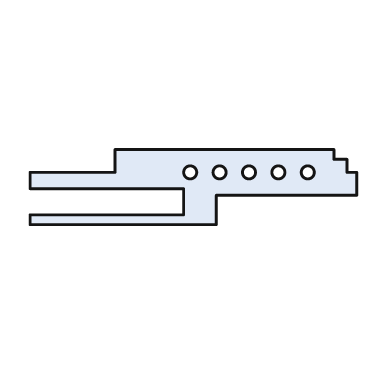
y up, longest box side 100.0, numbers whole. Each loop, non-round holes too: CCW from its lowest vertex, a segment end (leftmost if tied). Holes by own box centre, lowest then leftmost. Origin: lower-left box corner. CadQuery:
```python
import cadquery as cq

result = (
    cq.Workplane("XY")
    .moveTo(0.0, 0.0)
    .lineTo(57.0, 0.0)
    .lineTo(57.0, 9.0)
    .lineTo(100.0, 9.0)
    .lineTo(100.0, 16.0)
    .lineTo(97.0, 16.0)
    .lineTo(97.0, 20.0)
    .lineTo(93.0, 20.0)
    .lineTo(93.0, 23.0)
    .lineTo(26.0, 23.0)
    .lineTo(26.0, 16.0)
    .lineTo(0.0, 16.0)
    .lineTo(0.0, 11.0)
    .lineTo(47.0, 11.0)
    .lineTo(47.0, 3.0)
    .lineTo(0.0, 3.0)
    .close()
    .moveTo(49.0, 16.0)
    .circle(2.0)
    .moveTo(58.0, 16.0)
    .circle(2.0)
    .moveTo(67.0, 16.0)
    .circle(2.0)
    .moveTo(76.0, 16.0)
    .circle(2.0)
    .moveTo(85.0, 16.0)
    .circle(2.0)
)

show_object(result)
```